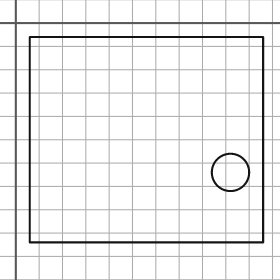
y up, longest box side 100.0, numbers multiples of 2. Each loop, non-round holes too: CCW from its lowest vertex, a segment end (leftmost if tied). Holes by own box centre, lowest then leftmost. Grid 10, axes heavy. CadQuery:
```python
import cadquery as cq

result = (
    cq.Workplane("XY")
    .moveTo(6.0, -94.0)
    .lineTo(106.0, -94.0)
    .lineTo(106.0, -6.0)
    .lineTo(6.0, -6.0)
    .close()
    .moveTo(92.0, -64.0)
    .circle(8.0)
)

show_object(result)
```